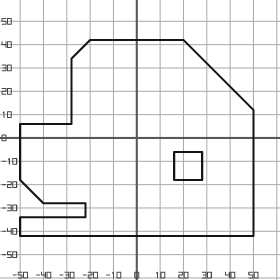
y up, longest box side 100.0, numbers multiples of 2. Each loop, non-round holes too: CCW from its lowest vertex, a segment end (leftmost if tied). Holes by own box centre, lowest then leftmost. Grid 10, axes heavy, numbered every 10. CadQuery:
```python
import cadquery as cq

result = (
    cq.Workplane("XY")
    .moveTo(-50.0, -42.0)
    .lineTo(50.0, -42.0)
    .lineTo(50.0, 12.0)
    .lineTo(20.0, 42.0)
    .lineTo(-20.0, 42.0)
    .lineTo(-28.0, 34.0)
    .lineTo(-28.0, 6.0)
    .lineTo(-50.0, 6.0)
    .lineTo(-50.0, -18.0)
    .lineTo(-40.0, -28.0)
    .lineTo(-22.0, -28.0)
    .lineTo(-22.0, -34.0)
    .lineTo(-50.0, -34.0)
    .close()
    .moveTo(16.0, -18.0)
    .lineTo(28.0, -18.0)
    .lineTo(28.0, -6.0)
    .lineTo(16.0, -6.0)
    .close()
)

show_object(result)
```